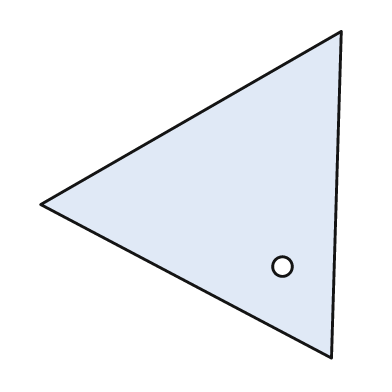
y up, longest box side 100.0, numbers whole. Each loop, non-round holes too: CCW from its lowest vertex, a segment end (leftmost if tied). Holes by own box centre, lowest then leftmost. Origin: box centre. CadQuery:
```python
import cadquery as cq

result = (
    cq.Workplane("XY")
    .moveTo(43.0, -50.0)
    .lineTo(46.0, 50.0)
    .lineTo(-46.0, -3.0)
    .close()
    .moveTo(28.0, -22.0)
    .circle(3.0)
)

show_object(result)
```